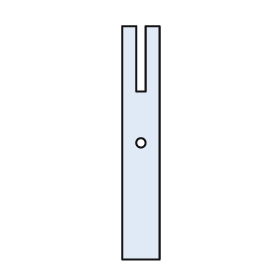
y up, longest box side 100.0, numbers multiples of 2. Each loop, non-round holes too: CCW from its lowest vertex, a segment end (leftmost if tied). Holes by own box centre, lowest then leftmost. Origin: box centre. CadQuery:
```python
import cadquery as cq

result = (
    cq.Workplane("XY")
    .moveTo(-8.0, -50.0)
    .lineTo(8.0, -50.0)
    .lineTo(8.0, 50.0)
    .lineTo(2.0, 50.0)
    .lineTo(2.0, 22.0)
    .lineTo(-2.0, 22.0)
    .lineTo(-2.0, 50.0)
    .lineTo(-8.0, 50.0)
    .close()
    .moveTo(0.0, 0.0)
    .circle(2.0)
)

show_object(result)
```